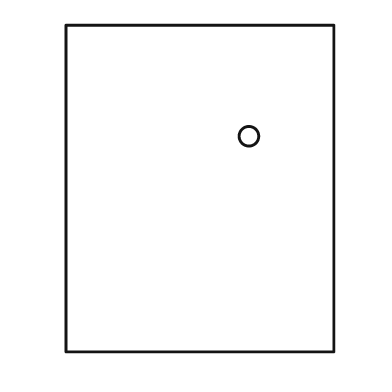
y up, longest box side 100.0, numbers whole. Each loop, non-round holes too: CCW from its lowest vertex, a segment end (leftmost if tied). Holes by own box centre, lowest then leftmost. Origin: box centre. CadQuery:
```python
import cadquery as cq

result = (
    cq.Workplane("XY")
    .moveTo(-41.0, -50.0)
    .lineTo(41.0, -50.0)
    .lineTo(41.0, 50.0)
    .lineTo(-41.0, 50.0)
    .close()
    .moveTo(15.0, 16.0)
    .circle(3.0)
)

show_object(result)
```